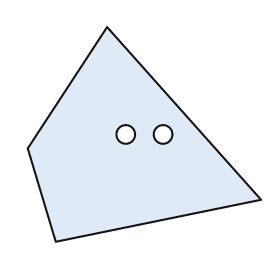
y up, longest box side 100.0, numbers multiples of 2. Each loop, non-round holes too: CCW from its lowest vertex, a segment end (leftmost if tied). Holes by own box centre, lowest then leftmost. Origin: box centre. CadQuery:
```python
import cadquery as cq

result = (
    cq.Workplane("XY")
    .moveTo(-38.0, -46.0)
    .lineTo(50.0, -28.0)
    .lineTo(-16.0, 46.0)
    .lineTo(-50.0, -6.0)
    .close()
    .moveTo(-8.0, 0.0)
    .circle(4.0)
    .moveTo(8.0, 0.0)
    .circle(4.0)
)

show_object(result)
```